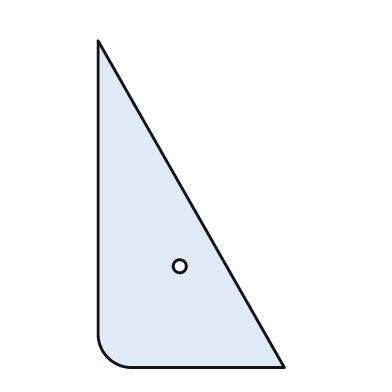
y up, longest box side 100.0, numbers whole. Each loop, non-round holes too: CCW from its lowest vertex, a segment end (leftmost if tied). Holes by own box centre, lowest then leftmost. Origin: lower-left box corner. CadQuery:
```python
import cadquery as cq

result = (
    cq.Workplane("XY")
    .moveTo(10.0, 0.0)
    .lineTo(57.0, 0.0)
    .lineTo(0.0, 100.0)
    .lineTo(0.0, 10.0)
    .threePointArc((3.0, 3.0), (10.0, 0.0))
    .close()
    .moveTo(25.0, 31.0)
    .circle(2.0)
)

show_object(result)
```